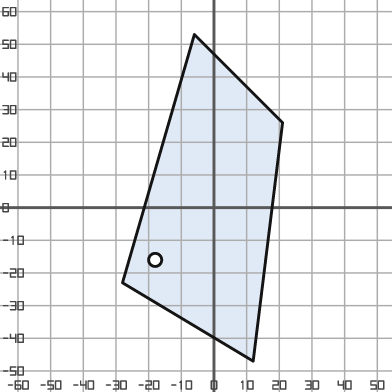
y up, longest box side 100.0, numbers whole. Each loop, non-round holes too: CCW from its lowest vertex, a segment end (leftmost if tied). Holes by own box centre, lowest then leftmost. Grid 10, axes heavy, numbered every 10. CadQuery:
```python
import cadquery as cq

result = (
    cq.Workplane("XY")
    .moveTo(12.0, -47.0)
    .lineTo(21.0, 26.0)
    .lineTo(-6.0, 53.0)
    .lineTo(-28.0, -23.0)
    .close()
    .moveTo(-18.0, -16.0)
    .circle(2.0)
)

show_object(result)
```